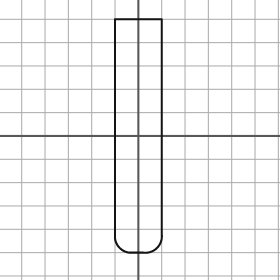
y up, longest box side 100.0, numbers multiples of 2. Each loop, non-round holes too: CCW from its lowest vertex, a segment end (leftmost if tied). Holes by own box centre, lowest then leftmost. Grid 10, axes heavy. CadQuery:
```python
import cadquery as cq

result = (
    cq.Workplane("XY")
    .moveTo(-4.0, -50.0)
    .lineTo(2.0, -50.0)
    .threePointArc((8.0, -48.0), (10.0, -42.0))
    .lineTo(10.0, 50.0)
    .lineTo(-10.0, 50.0)
    .lineTo(-10.0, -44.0)
    .threePointArc((-8.0, -48.0), (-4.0, -50.0))
    .close()
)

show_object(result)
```